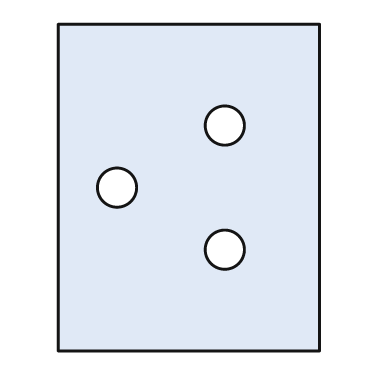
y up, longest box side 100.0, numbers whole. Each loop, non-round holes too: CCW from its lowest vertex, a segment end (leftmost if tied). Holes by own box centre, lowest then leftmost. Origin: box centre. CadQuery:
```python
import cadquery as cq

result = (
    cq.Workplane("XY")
    .moveTo(-40.0, -50.0)
    .lineTo(40.0, -50.0)
    .lineTo(40.0, 50.0)
    .lineTo(-40.0, 50.0)
    .close()
    .moveTo(11.0, -19.0)
    .circle(6.0)
    .moveTo(-22.0, 0.0)
    .circle(6.0)
    .moveTo(11.0, 19.0)
    .circle(6.0)
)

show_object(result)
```